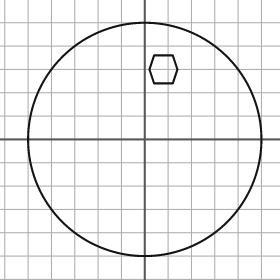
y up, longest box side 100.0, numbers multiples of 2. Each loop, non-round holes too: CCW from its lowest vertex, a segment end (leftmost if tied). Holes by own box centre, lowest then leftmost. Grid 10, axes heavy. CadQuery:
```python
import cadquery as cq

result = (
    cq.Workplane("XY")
    .moveTo(0.0, 0.0)
    .circle(50.0)
    .moveTo(4.0, 24.0)
    .lineTo(12.0, 24.0)
    .lineTo(14.0, 30.0)
    .lineTo(12.0, 36.0)
    .lineTo(4.0, 36.0)
    .lineTo(2.0, 30.0)
    .close()
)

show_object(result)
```